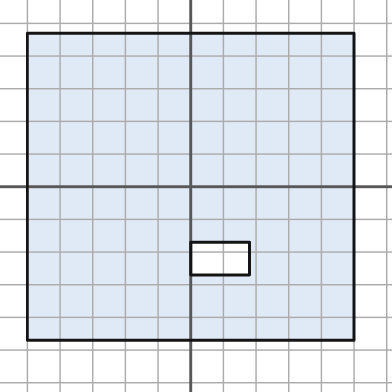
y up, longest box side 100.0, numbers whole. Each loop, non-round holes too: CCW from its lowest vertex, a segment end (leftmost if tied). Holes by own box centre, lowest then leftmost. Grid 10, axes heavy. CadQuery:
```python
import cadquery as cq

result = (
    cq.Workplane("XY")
    .moveTo(-50.0, -47.0)
    .lineTo(50.0, -47.0)
    .lineTo(50.0, 47.0)
    .lineTo(-50.0, 47.0)
    .close()
    .moveTo(0.0, -27.0)
    .lineTo(18.0, -27.0)
    .lineTo(18.0, -17.0)
    .lineTo(0.0, -17.0)
    .close()
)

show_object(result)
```